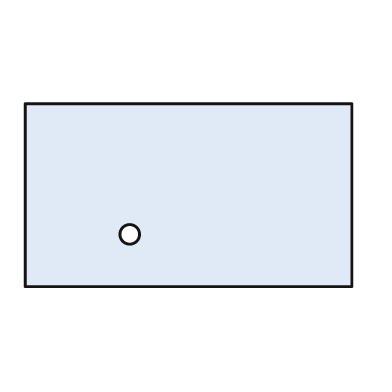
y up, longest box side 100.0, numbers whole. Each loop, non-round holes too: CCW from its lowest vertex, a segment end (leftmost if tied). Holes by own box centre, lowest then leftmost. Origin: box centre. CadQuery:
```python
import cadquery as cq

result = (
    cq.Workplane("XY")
    .moveTo(-50.0, -28.0)
    .lineTo(50.0, -28.0)
    .lineTo(50.0, 28.0)
    .lineTo(-50.0, 28.0)
    .close()
    .moveTo(-18.0, -12.0)
    .circle(3.0)
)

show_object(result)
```